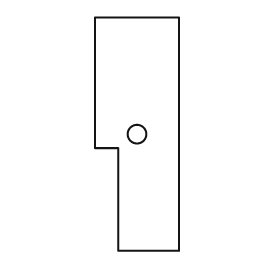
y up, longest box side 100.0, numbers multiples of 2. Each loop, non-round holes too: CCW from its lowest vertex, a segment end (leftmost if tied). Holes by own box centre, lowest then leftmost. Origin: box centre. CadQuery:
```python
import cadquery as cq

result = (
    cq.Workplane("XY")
    .moveTo(-8.0, -50.0)
    .lineTo(18.0, -50.0)
    .lineTo(18.0, 50.0)
    .lineTo(-18.0, 50.0)
    .lineTo(-18.0, -6.0)
    .lineTo(-8.0, -6.0)
    .close()
    .moveTo(0.0, 0.0)
    .circle(4.0)
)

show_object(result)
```